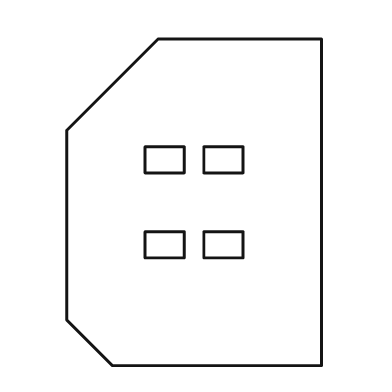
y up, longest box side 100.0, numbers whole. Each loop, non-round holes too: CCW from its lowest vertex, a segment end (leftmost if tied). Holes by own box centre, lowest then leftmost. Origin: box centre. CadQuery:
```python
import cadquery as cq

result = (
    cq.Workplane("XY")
    .moveTo(-25.0, -50.0)
    .lineTo(39.0, -50.0)
    .lineTo(39.0, 50.0)
    .lineTo(-11.0, 50.0)
    .lineTo(-39.0, 22.0)
    .lineTo(-39.0, -36.0)
    .close()
    .moveTo(-15.0, -17.0)
    .lineTo(-3.0, -17.0)
    .lineTo(-3.0, -9.0)
    .lineTo(-15.0, -9.0)
    .close()
    .moveTo(3.0, -17.0)
    .lineTo(15.0, -17.0)
    .lineTo(15.0, -9.0)
    .lineTo(3.0, -9.0)
    .close()
    .moveTo(-15.0, 9.0)
    .lineTo(-3.0, 9.0)
    .lineTo(-3.0, 17.0)
    .lineTo(-15.0, 17.0)
    .close()
    .moveTo(3.0, 9.0)
    .lineTo(15.0, 9.0)
    .lineTo(15.0, 17.0)
    .lineTo(3.0, 17.0)
    .close()
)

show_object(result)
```